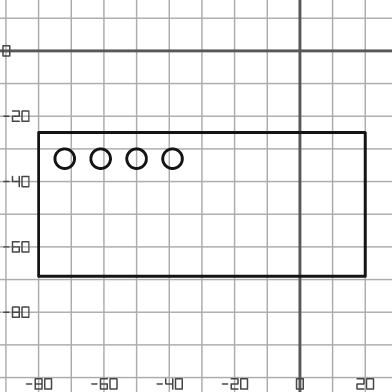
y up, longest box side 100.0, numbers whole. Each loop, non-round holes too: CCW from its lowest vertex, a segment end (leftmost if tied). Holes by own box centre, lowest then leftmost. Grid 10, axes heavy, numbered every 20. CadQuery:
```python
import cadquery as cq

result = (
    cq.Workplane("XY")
    .moveTo(-80.0, -69.0)
    .lineTo(20.0, -69.0)
    .lineTo(20.0, -25.0)
    .lineTo(-80.0, -25.0)
    .close()
    .moveTo(-72.0, -33.0)
    .circle(3.0)
    .moveTo(-61.0, -33.0)
    .circle(3.0)
    .moveTo(-50.0, -33.0)
    .circle(3.0)
    .moveTo(-39.0, -33.0)
    .circle(3.0)
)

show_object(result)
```